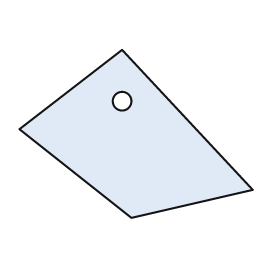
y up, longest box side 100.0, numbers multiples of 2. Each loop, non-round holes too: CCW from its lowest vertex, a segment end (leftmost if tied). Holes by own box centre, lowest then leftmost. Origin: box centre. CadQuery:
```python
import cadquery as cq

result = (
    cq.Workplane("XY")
    .moveTo(-2.0, -36.0)
    .lineTo(50.0, -24.0)
    .lineTo(-6.0, 36.0)
    .lineTo(-50.0, 2.0)
    .close()
    .moveTo(-6.0, 14.0)
    .circle(4.0)
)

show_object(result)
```